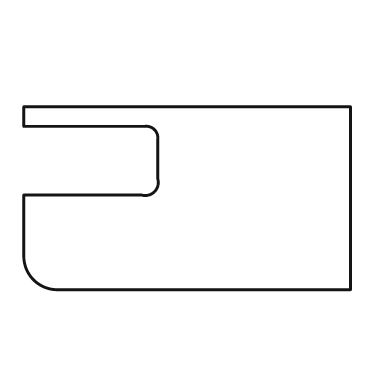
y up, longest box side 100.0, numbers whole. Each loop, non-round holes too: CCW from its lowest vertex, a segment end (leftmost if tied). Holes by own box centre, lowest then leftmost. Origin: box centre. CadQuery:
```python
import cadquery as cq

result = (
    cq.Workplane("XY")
    .moveTo(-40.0, -28.0)
    .lineTo(50.0, -28.0)
    .lineTo(50.0, 28.0)
    .lineTo(-50.0, 28.0)
    .lineTo(-50.0, 22.0)
    .lineTo(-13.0, 22.0)
    .threePointArc((-10.0, 21.0), (-9.0, 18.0))
    .lineTo(-9.0, 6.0)
    .threePointArc((-10.0, 2.0), (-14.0, 1.0))
    .lineTo(-50.0, 1.0)
    .lineTo(-50.0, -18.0)
    .threePointArc((-47.0, -25.0), (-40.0, -28.0))
    .close()
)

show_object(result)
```